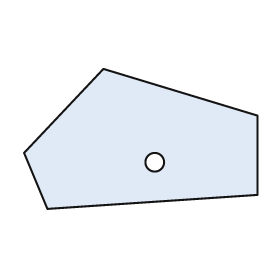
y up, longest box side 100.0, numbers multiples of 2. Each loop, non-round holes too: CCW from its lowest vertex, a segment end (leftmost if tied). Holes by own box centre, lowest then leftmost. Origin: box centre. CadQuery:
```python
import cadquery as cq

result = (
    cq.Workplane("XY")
    .moveTo(-40.0, -30.0)
    .lineTo(50.0, -24.0)
    .lineTo(50.0, 10.0)
    .lineTo(-16.0, 30.0)
    .lineTo(-50.0, -6.0)
    .close()
    .moveTo(6.0, -10.0)
    .circle(4.0)
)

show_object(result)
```